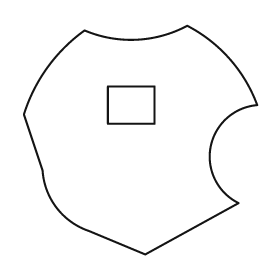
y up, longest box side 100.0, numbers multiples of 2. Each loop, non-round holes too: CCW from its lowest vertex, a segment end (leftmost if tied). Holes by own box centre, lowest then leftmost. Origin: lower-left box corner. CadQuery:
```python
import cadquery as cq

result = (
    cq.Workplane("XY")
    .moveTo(52.0, 0.0)
    .lineTo(92.0, 22.0)
    .threePointArc((80.0, 46.0), (100.0, 64.0))
    .threePointArc((88.0, 84.0), (70.0, 98.0))
    .threePointArc((48.0, 92.0), (26.0, 96.0))
    .threePointArc((10.0, 80.0), (0.0, 60.0))
    .lineTo(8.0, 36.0)
    .threePointArc((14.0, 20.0), (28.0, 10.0))
    .close()
    .moveTo(36.0, 56.0)
    .lineTo(56.0, 56.0)
    .lineTo(56.0, 72.0)
    .lineTo(36.0, 72.0)
    .close()
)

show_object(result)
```